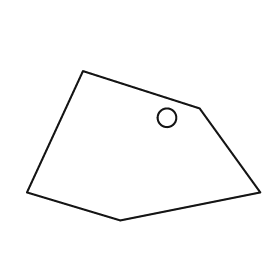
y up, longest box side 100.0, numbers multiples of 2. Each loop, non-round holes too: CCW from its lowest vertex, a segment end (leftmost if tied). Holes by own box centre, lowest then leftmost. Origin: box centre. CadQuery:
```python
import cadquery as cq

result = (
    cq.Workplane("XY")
    .moveTo(-10.0, -32.0)
    .lineTo(50.0, -20.0)
    .lineTo(24.0, 16.0)
    .lineTo(-26.0, 32.0)
    .lineTo(-50.0, -20.0)
    .close()
    .moveTo(10.0, 12.0)
    .circle(4.0)
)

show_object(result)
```